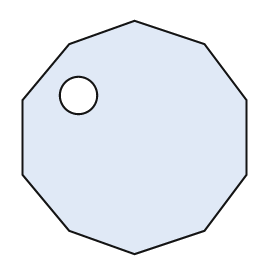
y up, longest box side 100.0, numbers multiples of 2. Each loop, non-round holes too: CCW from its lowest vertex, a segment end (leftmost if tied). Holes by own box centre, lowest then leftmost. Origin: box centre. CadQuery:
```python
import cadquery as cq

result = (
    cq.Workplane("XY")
    .moveTo(0.0, -50.0)
    .lineTo(30.0, -40.0)
    .lineTo(48.0, -16.0)
    .lineTo(48.0, 16.0)
    .lineTo(30.0, 40.0)
    .lineTo(0.0, 50.0)
    .lineTo(-28.0, 40.0)
    .lineTo(-48.0, 16.0)
    .lineTo(-48.0, -16.0)
    .lineTo(-28.0, -40.0)
    .close()
    .moveTo(-24.0, 18.0)
    .circle(8.0)
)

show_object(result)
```